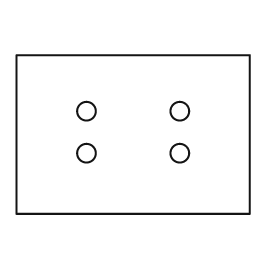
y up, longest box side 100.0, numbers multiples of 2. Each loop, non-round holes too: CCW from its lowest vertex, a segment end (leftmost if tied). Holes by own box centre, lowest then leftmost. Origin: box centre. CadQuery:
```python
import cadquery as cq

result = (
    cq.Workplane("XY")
    .moveTo(-50.0, -34.0)
    .lineTo(50.0, -34.0)
    .lineTo(50.0, 34.0)
    .lineTo(-50.0, 34.0)
    .close()
    .moveTo(-20.0, -8.0)
    .circle(4.0)
    .moveTo(20.0, -8.0)
    .circle(4.0)
    .moveTo(-20.0, 10.0)
    .circle(4.0)
    .moveTo(20.0, 10.0)
    .circle(4.0)
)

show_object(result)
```